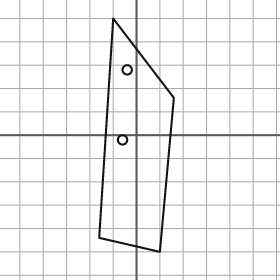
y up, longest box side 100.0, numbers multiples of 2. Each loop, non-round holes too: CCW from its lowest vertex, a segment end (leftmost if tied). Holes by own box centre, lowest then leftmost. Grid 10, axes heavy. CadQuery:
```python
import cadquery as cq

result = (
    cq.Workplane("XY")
    .moveTo(10.0, -50.0)
    .lineTo(16.0, 16.0)
    .lineTo(-10.0, 50.0)
    .lineTo(-16.0, -44.0)
    .close()
    .moveTo(-6.0, -2.0)
    .circle(2.0)
    .moveTo(-4.0, 28.0)
    .circle(2.0)
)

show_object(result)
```